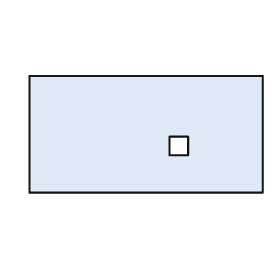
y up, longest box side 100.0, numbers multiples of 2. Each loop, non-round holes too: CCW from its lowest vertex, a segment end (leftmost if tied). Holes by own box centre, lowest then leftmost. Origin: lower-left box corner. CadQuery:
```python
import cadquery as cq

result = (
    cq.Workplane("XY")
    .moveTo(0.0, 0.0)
    .lineTo(100.0, 0.0)
    .lineTo(100.0, 50.0)
    .lineTo(0.0, 50.0)
    .close()
    .moveTo(60.0, 16.0)
    .lineTo(68.0, 16.0)
    .lineTo(68.0, 24.0)
    .lineTo(60.0, 24.0)
    .close()
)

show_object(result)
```